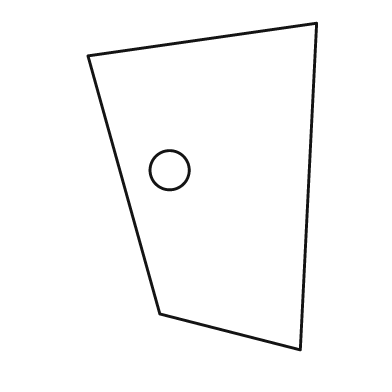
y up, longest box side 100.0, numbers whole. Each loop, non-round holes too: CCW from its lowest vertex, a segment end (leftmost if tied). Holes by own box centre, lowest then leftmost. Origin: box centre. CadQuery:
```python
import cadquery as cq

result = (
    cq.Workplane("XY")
    .moveTo(30.0, -50.0)
    .lineTo(35.0, 50.0)
    .lineTo(-35.0, 40.0)
    .lineTo(-13.0, -39.0)
    .close()
    .moveTo(-10.0, 5.0)
    .circle(6.0)
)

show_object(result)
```